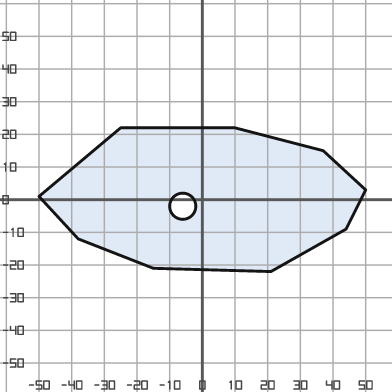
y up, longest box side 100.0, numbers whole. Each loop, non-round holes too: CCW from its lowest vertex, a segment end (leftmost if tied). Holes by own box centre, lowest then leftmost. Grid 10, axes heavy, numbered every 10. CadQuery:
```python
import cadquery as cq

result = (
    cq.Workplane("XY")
    .moveTo(21.0, -22.0)
    .lineTo(44.0, -9.0)
    .lineTo(50.0, 3.0)
    .lineTo(37.0, 15.0)
    .lineTo(10.0, 22.0)
    .lineTo(-25.0, 22.0)
    .lineTo(-50.0, 1.0)
    .lineTo(-38.0, -12.0)
    .lineTo(-15.0, -21.0)
    .close()
    .moveTo(-6.0, -2.0)
    .circle(4.0)
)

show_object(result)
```